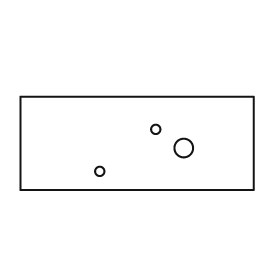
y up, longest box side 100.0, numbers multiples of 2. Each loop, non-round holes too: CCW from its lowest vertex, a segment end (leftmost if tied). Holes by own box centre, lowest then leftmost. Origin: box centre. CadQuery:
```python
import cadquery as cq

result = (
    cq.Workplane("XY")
    .moveTo(-50.0, -20.0)
    .lineTo(50.0, -20.0)
    .lineTo(50.0, 20.0)
    .lineTo(-50.0, 20.0)
    .close()
    .moveTo(-16.0, -12.0)
    .circle(2.0)
    .moveTo(20.0, -2.0)
    .circle(4.0)
    .moveTo(8.0, 6.0)
    .circle(2.0)
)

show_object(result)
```